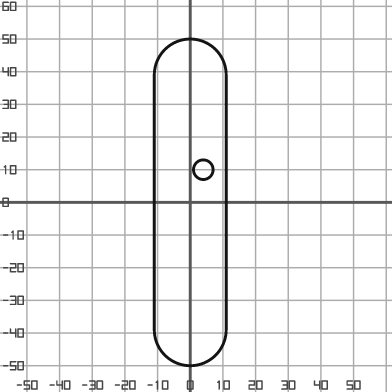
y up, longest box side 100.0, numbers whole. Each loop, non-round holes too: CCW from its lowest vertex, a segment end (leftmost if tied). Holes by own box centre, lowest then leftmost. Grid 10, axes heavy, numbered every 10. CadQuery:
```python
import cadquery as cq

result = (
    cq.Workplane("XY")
    .moveTo(-11.0, -39.0)
    .threePointArc((0.0, -50.0), (11.0, -39.0))
    .lineTo(11.0, 39.0)
    .threePointArc((0.0, 50.0), (-11.0, 39.0))
    .close()
    .moveTo(4.0, 10.0)
    .circle(3.0)
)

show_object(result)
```